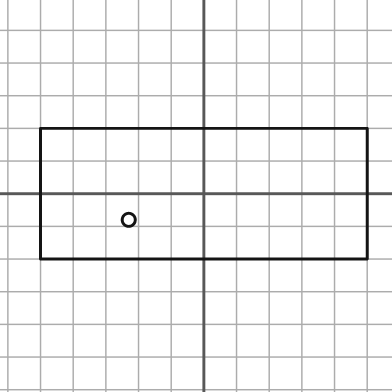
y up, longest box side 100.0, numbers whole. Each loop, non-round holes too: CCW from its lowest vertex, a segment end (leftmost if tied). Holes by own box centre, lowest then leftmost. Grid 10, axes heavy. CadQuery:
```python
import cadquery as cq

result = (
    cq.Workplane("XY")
    .moveTo(-50.0, -20.0)
    .lineTo(50.0, -20.0)
    .lineTo(50.0, 20.0)
    .lineTo(-50.0, 20.0)
    .close()
    .moveTo(-23.0, -8.0)
    .circle(2.0)
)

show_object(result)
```